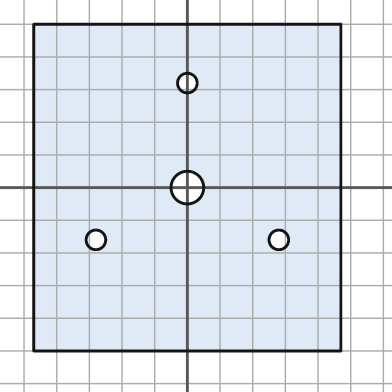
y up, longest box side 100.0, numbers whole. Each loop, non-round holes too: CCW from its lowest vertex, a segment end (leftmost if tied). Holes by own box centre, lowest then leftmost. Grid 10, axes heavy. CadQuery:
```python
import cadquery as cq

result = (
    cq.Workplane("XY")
    .moveTo(-47.0, -50.0)
    .lineTo(47.0, -50.0)
    .lineTo(47.0, 50.0)
    .lineTo(-47.0, 50.0)
    .close()
    .moveTo(-28.0, -16.0)
    .circle(3.0)
    .moveTo(28.0, -16.0)
    .circle(3.0)
    .moveTo(0.0, 0.0)
    .circle(5.0)
    .moveTo(0.0, 32.0)
    .circle(3.0)
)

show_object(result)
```